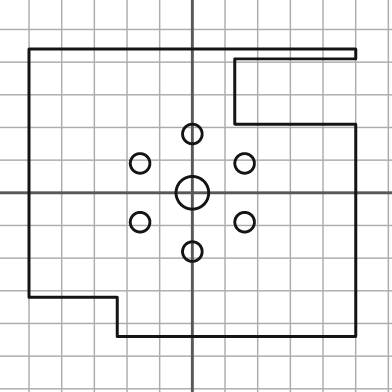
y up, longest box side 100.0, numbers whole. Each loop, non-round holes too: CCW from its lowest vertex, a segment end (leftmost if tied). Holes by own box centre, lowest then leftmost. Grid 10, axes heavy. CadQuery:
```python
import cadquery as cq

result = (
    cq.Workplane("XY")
    .moveTo(-23.0, -44.0)
    .lineTo(50.0, -44.0)
    .lineTo(50.0, 21.0)
    .lineTo(13.0, 21.0)
    .lineTo(13.0, 41.0)
    .lineTo(50.0, 41.0)
    .lineTo(50.0, 44.0)
    .lineTo(-50.0, 44.0)
    .lineTo(-50.0, -32.0)
    .lineTo(-23.0, -32.0)
    .close()
    .moveTo(0.0, -18.0)
    .circle(3.0)
    .moveTo(-16.0, -9.0)
    .circle(3.0)
    .moveTo(16.0, -9.0)
    .circle(3.0)
    .moveTo(0.0, 0.0)
    .circle(5.0)
    .moveTo(-16.0, 9.0)
    .circle(3.0)
    .moveTo(16.0, 9.0)
    .circle(3.0)
    .moveTo(0.0, 18.0)
    .circle(3.0)
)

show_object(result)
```